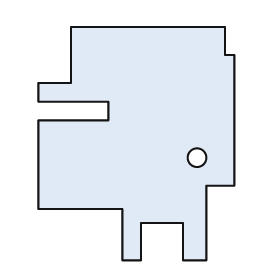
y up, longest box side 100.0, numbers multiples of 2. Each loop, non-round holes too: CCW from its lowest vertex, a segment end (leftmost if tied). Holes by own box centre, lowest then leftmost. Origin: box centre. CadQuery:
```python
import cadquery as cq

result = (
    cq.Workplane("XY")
    .moveTo(-6.0, -50.0)
    .lineTo(2.0, -50.0)
    .lineTo(2.0, -34.0)
    .lineTo(20.0, -34.0)
    .lineTo(20.0, -50.0)
    .lineTo(30.0, -50.0)
    .lineTo(30.0, -18.0)
    .lineTo(42.0, -18.0)
    .lineTo(42.0, 38.0)
    .lineTo(38.0, 38.0)
    .lineTo(38.0, 50.0)
    .lineTo(-28.0, 50.0)
    .lineTo(-28.0, 26.0)
    .lineTo(-42.0, 26.0)
    .lineTo(-42.0, 18.0)
    .lineTo(-12.0, 18.0)
    .lineTo(-12.0, 10.0)
    .lineTo(-42.0, 10.0)
    .lineTo(-42.0, -28.0)
    .lineTo(-6.0, -28.0)
    .close()
    .moveTo(26.0, -6.0)
    .circle(4.0)
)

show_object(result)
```